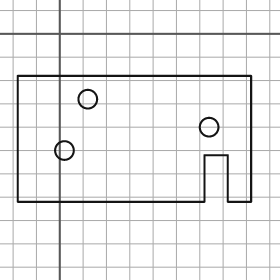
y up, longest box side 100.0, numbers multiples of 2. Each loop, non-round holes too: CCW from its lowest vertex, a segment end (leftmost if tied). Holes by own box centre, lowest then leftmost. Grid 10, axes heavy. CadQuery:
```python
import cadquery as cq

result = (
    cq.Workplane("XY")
    .moveTo(-18.0, -72.0)
    .lineTo(62.0, -72.0)
    .lineTo(62.0, -52.0)
    .lineTo(72.0, -52.0)
    .lineTo(72.0, -72.0)
    .lineTo(82.0, -72.0)
    .lineTo(82.0, -18.0)
    .lineTo(-18.0, -18.0)
    .close()
    .moveTo(2.0, -50.0)
    .circle(4.0)
    .moveTo(64.0, -40.0)
    .circle(4.0)
    .moveTo(12.0, -28.0)
    .circle(4.0)
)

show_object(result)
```